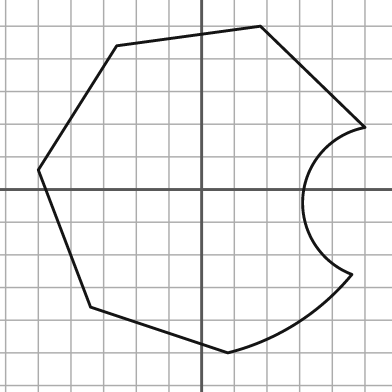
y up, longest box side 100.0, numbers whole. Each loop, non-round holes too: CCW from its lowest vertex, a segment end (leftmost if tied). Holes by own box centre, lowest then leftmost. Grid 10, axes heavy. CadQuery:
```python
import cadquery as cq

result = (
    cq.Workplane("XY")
    .moveTo(8.0, -50.0)
    .threePointArc((29.0, -41.0), (46.0, -26.0))
    .threePointArc((31.0, -2.0), (50.0, 19.0))
    .lineTo(18.0, 50.0)
    .lineTo(-26.0, 44.0)
    .lineTo(-50.0, 6.0)
    .lineTo(-34.0, -36.0)
    .close()
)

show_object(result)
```